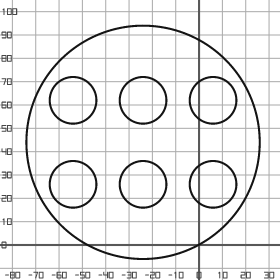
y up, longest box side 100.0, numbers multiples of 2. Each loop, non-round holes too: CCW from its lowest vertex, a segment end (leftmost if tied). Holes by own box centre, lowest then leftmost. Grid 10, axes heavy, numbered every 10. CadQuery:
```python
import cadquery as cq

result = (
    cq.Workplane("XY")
    .moveTo(-24.0, 44.0)
    .circle(50.0)
    .moveTo(-54.0, 26.0)
    .circle(10.0)
    .moveTo(-24.0, 26.0)
    .circle(10.0)
    .moveTo(6.0, 26.0)
    .circle(10.0)
    .moveTo(-54.0, 62.0)
    .circle(10.0)
    .moveTo(-24.0, 62.0)
    .circle(10.0)
    .moveTo(6.0, 62.0)
    .circle(10.0)
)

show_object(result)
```